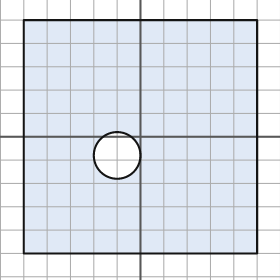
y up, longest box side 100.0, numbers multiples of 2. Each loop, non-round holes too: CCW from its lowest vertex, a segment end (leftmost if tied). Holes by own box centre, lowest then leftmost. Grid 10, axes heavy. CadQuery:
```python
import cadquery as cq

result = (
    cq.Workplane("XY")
    .moveTo(-50.0, -50.0)
    .lineTo(50.0, -50.0)
    .lineTo(50.0, 50.0)
    .lineTo(-50.0, 50.0)
    .close()
    .moveTo(-10.0, -8.0)
    .circle(10.0)
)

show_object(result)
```